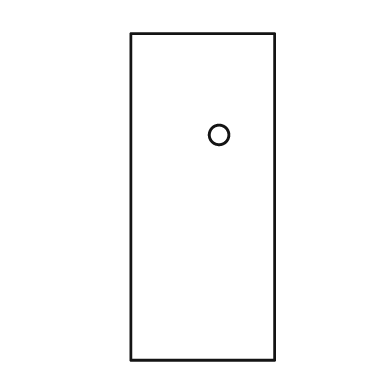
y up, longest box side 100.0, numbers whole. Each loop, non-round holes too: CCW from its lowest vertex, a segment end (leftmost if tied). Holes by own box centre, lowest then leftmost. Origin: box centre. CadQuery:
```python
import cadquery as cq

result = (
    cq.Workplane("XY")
    .moveTo(-22.0, -50.0)
    .lineTo(22.0, -50.0)
    .lineTo(22.0, 50.0)
    .lineTo(-22.0, 50.0)
    .close()
    .moveTo(5.0, 19.0)
    .circle(3.0)
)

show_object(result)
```